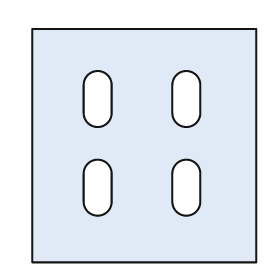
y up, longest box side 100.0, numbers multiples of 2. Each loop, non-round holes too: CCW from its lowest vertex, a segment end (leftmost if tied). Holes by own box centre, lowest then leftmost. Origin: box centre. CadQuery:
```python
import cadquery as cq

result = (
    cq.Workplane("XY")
    .moveTo(-48.0, -50.0)
    .lineTo(48.0, -50.0)
    .lineTo(48.0, 50.0)
    .lineTo(-48.0, 50.0)
    .close()
    .moveTo(-26.0, -24.0)
    .threePointArc((-20.0, -30.0), (-14.0, -24.0))
    .lineTo(-14.0, -12.0)
    .threePointArc((-20.0, -6.0), (-26.0, -12.0))
    .close()
    .moveTo(12.0, -24.0)
    .threePointArc((18.0, -30.0), (24.0, -24.0))
    .lineTo(24.0, -12.0)
    .threePointArc((18.0, -6.0), (12.0, -12.0))
    .close()
    .moveTo(-26.0, 14.0)
    .threePointArc((-20.0, 8.0), (-14.0, 14.0))
    .lineTo(-14.0, 26.0)
    .threePointArc((-20.0, 32.0), (-26.0, 26.0))
    .close()
    .moveTo(12.0, 14.0)
    .threePointArc((18.0, 8.0), (24.0, 14.0))
    .lineTo(24.0, 26.0)
    .threePointArc((18.0, 32.0), (12.0, 26.0))
    .close()
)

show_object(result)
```